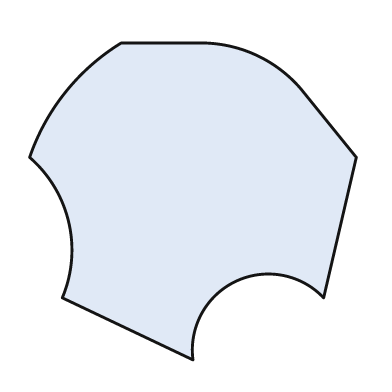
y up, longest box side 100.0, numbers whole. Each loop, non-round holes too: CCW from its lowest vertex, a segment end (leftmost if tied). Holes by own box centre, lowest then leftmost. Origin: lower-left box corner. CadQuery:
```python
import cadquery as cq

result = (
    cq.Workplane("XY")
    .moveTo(50.0, 0.0)
    .threePointArc((63.0, 24.0), (90.0, 19.0))
    .lineTo(100.0, 62.0)
    .lineTo(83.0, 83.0)
    .threePointArc((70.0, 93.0), (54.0, 97.0))
    .lineTo(28.0, 97.0)
    .threePointArc((11.0, 82.0), (0.0, 62.0))
    .threePointArc((12.0, 42.0), (10.0, 19.0))
    .close()
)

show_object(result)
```